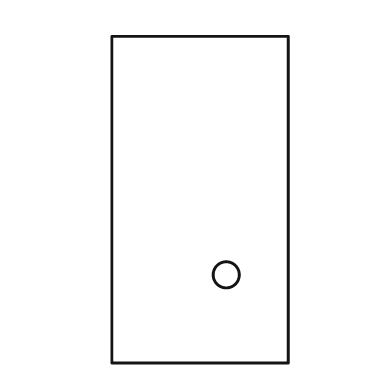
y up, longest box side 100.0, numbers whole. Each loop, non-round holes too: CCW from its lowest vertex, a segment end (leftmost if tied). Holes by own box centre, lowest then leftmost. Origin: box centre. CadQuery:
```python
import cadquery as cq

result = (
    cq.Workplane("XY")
    .moveTo(-27.0, -50.0)
    .lineTo(27.0, -50.0)
    .lineTo(27.0, 50.0)
    .lineTo(-27.0, 50.0)
    .close()
    .moveTo(8.0, -23.0)
    .circle(4.0)
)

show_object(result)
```